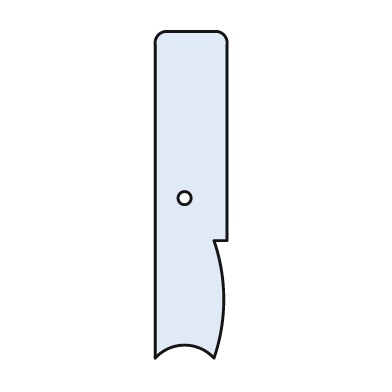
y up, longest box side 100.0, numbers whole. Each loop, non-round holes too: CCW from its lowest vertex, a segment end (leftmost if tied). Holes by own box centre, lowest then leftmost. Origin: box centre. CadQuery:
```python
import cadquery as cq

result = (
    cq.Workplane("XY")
    .moveTo(-11.0, -50.0)
    .threePointArc((-2.0, -46.0), (7.0, -50.0))
    .threePointArc((10.0, -32.0), (7.0, -14.0))
    .lineTo(11.0, -14.0)
    .lineTo(11.0, 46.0)
    .threePointArc((10.0, 49.0), (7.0, 50.0))
    .lineTo(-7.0, 50.0)
    .threePointArc((-10.0, 49.0), (-11.0, 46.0))
    .close()
    .moveTo(-2.0, -1.0)
    .circle(2.0)
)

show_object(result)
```